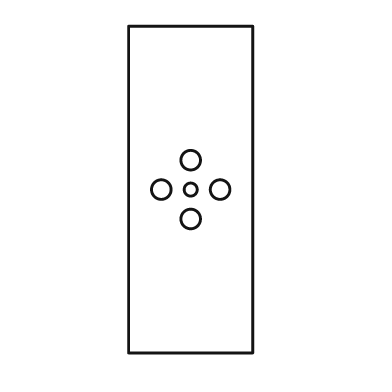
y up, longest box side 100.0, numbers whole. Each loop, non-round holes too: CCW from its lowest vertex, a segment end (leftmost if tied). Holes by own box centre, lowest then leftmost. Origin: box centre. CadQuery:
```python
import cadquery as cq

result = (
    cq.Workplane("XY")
    .moveTo(-19.0, -50.0)
    .lineTo(19.0, -50.0)
    .lineTo(19.0, 50.0)
    .lineTo(-19.0, 50.0)
    .close()
    .moveTo(0.0, -9.0)
    .circle(3.0)
    .moveTo(-9.0, 0.0)
    .circle(3.0)
    .moveTo(0.0, 0.0)
    .circle(2.0)
    .moveTo(9.0, 0.0)
    .circle(3.0)
    .moveTo(0.0, 9.0)
    .circle(3.0)
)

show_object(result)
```